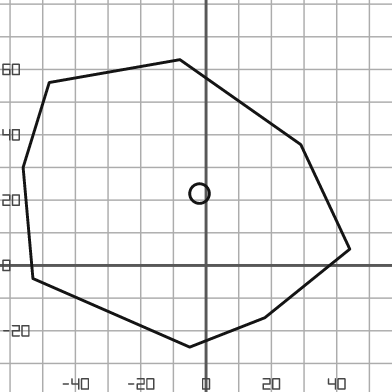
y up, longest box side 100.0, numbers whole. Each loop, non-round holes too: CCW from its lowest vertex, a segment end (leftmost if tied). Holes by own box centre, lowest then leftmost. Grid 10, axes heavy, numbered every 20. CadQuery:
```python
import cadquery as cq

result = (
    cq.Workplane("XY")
    .moveTo(-5.0, -25.0)
    .lineTo(18.0, -16.0)
    .lineTo(44.0, 5.0)
    .lineTo(29.0, 37.0)
    .lineTo(-8.0, 63.0)
    .lineTo(-48.0, 56.0)
    .lineTo(-56.0, 30.0)
    .lineTo(-53.0, -4.0)
    .close()
    .moveTo(-2.0, 22.0)
    .circle(3.0)
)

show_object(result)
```